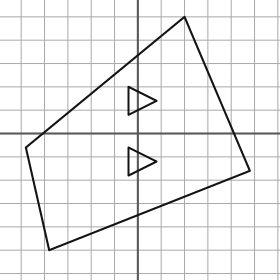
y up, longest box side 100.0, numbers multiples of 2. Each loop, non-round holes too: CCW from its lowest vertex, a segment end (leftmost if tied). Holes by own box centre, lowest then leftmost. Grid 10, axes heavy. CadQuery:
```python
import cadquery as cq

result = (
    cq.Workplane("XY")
    .moveTo(-38.0, -50.0)
    .lineTo(48.0, -16.0)
    .lineTo(20.0, 50.0)
    .lineTo(-48.0, -6.0)
    .close()
    .moveTo(-4.0, -18.0)
    .lineTo(8.0, -12.0)
    .lineTo(-4.0, -6.0)
    .close()
    .moveTo(-4.0, 8.0)
    .lineTo(8.0, 14.0)
    .lineTo(-4.0, 20.0)
    .close()
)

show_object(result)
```